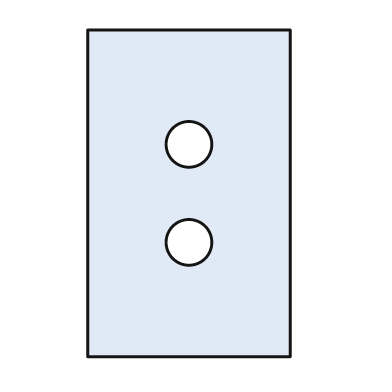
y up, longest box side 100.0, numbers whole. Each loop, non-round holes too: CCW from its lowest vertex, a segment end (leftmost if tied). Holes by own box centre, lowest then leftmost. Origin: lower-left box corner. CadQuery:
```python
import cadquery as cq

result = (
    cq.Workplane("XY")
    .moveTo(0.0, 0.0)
    .lineTo(62.0, 0.0)
    .lineTo(62.0, 100.0)
    .lineTo(0.0, 100.0)
    .close()
    .moveTo(31.0, 35.0)
    .circle(7.0)
    .moveTo(31.0, 65.0)
    .circle(7.0)
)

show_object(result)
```